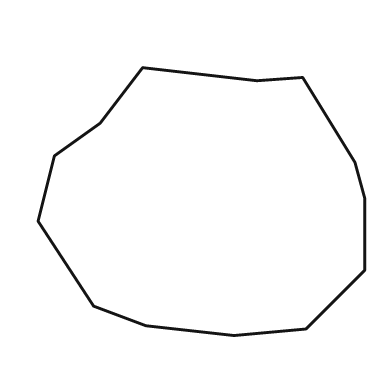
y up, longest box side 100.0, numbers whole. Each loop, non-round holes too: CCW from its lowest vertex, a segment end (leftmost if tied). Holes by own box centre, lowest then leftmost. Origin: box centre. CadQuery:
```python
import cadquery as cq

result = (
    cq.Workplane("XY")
    .moveTo(10.0, -41.0)
    .lineTo(32.0, -39.0)
    .lineTo(50.0, -21.0)
    .lineTo(50.0, 1.0)
    .lineTo(47.0, 12.0)
    .lineTo(31.0, 38.0)
    .lineTo(17.0, 37.0)
    .lineTo(-18.0, 41.0)
    .lineTo(-31.0, 24.0)
    .lineTo(-45.0, 14.0)
    .lineTo(-50.0, -6.0)
    .lineTo(-33.0, -32.0)
    .lineTo(-17.0, -38.0)
    .close()
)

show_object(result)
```